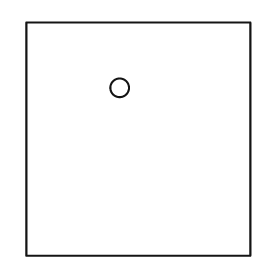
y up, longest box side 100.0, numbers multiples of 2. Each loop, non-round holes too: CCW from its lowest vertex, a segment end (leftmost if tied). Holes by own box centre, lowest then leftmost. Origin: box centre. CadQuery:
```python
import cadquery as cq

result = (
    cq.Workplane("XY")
    .moveTo(-48.0, -50.0)
    .lineTo(48.0, -50.0)
    .lineTo(48.0, 50.0)
    .lineTo(-48.0, 50.0)
    .close()
    .moveTo(-8.0, 22.0)
    .circle(4.0)
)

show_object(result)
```